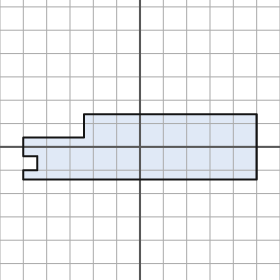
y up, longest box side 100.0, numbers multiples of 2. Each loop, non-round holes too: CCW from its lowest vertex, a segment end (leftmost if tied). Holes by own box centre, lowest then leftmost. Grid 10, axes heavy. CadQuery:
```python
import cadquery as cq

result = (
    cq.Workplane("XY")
    .moveTo(-50.0, -14.0)
    .lineTo(50.0, -14.0)
    .lineTo(50.0, 14.0)
    .lineTo(-24.0, 14.0)
    .lineTo(-24.0, 4.0)
    .lineTo(-50.0, 4.0)
    .lineTo(-50.0, -4.0)
    .lineTo(-44.0, -4.0)
    .lineTo(-44.0, -10.0)
    .lineTo(-50.0, -10.0)
    .close()
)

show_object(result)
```